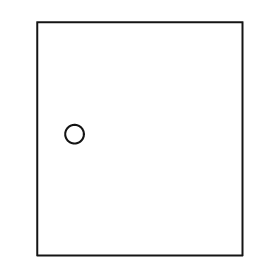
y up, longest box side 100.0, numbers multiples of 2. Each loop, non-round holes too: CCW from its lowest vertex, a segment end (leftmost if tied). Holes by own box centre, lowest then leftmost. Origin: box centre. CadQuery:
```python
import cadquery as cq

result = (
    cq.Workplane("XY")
    .moveTo(-44.0, -50.0)
    .lineTo(44.0, -50.0)
    .lineTo(44.0, 50.0)
    .lineTo(-44.0, 50.0)
    .close()
    .moveTo(-28.0, 2.0)
    .circle(4.0)
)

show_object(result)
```